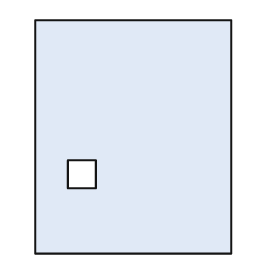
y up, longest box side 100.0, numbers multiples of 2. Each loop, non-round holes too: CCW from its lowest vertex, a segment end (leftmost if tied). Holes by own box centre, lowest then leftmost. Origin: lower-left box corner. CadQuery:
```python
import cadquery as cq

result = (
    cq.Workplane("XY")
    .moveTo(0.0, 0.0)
    .lineTo(84.0, 0.0)
    .lineTo(84.0, 100.0)
    .lineTo(0.0, 100.0)
    .close()
    .moveTo(14.0, 28.0)
    .lineTo(26.0, 28.0)
    .lineTo(26.0, 40.0)
    .lineTo(14.0, 40.0)
    .close()
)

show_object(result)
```